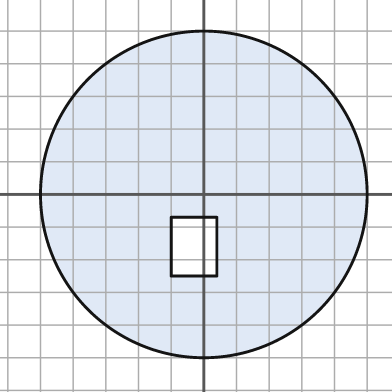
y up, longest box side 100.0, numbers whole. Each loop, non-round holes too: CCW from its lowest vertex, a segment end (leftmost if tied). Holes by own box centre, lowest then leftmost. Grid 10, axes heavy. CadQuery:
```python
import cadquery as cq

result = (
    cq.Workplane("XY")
    .moveTo(0.0, 0.0)
    .circle(50.0)
    .moveTo(-10.0, -25.0)
    .lineTo(4.0, -25.0)
    .lineTo(4.0, -7.0)
    .lineTo(-10.0, -7.0)
    .close()
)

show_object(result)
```